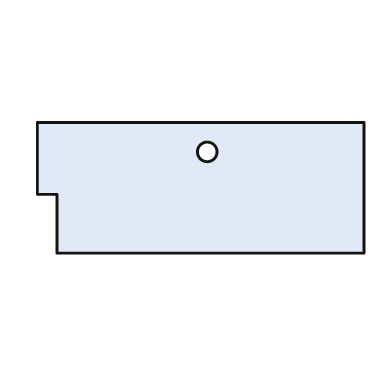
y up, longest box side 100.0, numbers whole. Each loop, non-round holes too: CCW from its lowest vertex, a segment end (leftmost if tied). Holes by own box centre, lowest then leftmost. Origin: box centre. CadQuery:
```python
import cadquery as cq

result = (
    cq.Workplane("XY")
    .moveTo(-44.0, -20.0)
    .lineTo(50.0, -20.0)
    .lineTo(50.0, 20.0)
    .lineTo(-50.0, 20.0)
    .lineTo(-50.0, -2.0)
    .lineTo(-44.0, -2.0)
    .close()
    .moveTo(2.0, 11.0)
    .circle(3.0)
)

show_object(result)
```